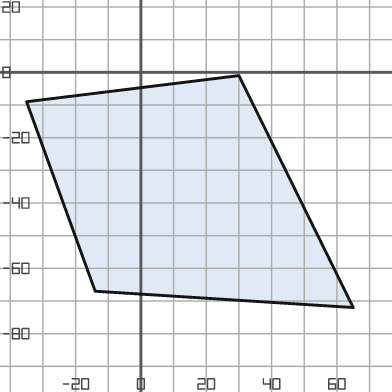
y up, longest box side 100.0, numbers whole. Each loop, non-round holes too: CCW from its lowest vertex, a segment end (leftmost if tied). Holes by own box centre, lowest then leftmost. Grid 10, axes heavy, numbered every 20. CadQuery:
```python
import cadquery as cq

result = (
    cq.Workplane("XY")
    .moveTo(65.0, -72.0)
    .lineTo(30.0, -1.0)
    .lineTo(-35.0, -9.0)
    .lineTo(-14.0, -67.0)
    .close()
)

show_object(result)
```